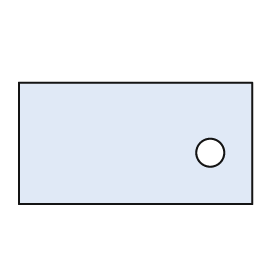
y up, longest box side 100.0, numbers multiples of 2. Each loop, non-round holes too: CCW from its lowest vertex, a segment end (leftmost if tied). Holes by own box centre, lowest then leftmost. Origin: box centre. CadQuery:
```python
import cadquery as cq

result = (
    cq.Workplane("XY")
    .moveTo(-50.0, -26.0)
    .lineTo(50.0, -26.0)
    .lineTo(50.0, 26.0)
    .lineTo(-50.0, 26.0)
    .close()
    .moveTo(32.0, -4.0)
    .circle(6.0)
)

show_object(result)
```